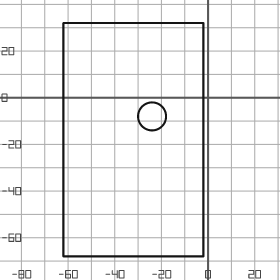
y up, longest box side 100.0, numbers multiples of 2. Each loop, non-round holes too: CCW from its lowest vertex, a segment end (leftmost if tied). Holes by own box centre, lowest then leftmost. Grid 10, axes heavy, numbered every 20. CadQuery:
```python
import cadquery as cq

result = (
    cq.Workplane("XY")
    .moveTo(-62.0, -68.0)
    .lineTo(-2.0, -68.0)
    .lineTo(-2.0, 32.0)
    .lineTo(-62.0, 32.0)
    .close()
    .moveTo(-24.0, -8.0)
    .circle(6.0)
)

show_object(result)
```